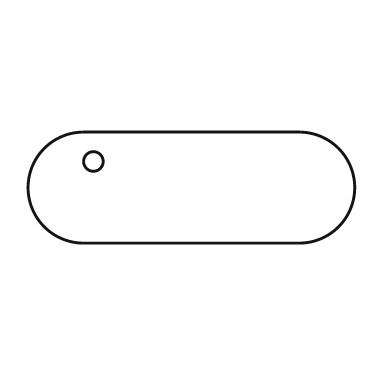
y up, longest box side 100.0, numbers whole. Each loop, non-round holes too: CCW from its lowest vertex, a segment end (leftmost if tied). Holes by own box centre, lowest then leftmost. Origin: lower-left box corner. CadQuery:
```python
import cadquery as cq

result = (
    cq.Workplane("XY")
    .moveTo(17.0, 0.0)
    .lineTo(83.0, 0.0)
    .threePointArc((100.0, 17.0), (83.0, 34.0))
    .lineTo(17.0, 34.0)
    .threePointArc((0.0, 17.0), (17.0, 0.0))
    .close()
    .moveTo(20.0, 25.0)
    .circle(3.0)
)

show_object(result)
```